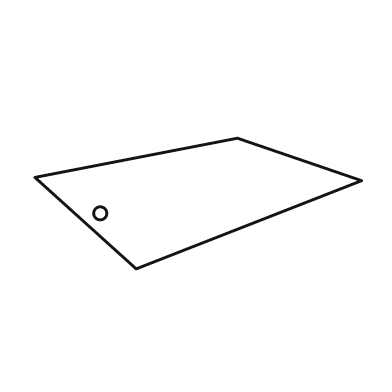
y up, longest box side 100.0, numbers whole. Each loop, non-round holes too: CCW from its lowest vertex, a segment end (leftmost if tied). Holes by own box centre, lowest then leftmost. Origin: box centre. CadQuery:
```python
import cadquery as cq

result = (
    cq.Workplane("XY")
    .moveTo(-19.0, -20.0)
    .lineTo(50.0, 7.0)
    .lineTo(12.0, 20.0)
    .lineTo(-50.0, 8.0)
    .close()
    .moveTo(-30.0, -3.0)
    .circle(2.0)
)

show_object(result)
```